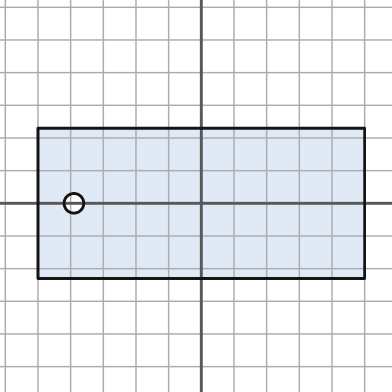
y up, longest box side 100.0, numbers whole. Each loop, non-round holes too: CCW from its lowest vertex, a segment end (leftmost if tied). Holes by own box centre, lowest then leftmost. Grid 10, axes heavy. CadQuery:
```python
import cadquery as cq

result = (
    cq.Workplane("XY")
    .moveTo(-50.0, -23.0)
    .lineTo(50.0, -23.0)
    .lineTo(50.0, 23.0)
    .lineTo(-50.0, 23.0)
    .close()
    .moveTo(-39.0, 0.0)
    .circle(3.0)
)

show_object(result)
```